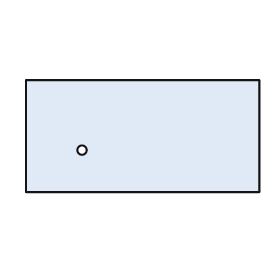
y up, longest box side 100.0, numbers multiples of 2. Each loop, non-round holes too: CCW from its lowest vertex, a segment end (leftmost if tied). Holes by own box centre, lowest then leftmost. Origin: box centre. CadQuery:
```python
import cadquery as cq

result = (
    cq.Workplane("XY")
    .moveTo(-50.0, -24.0)
    .lineTo(50.0, -24.0)
    .lineTo(50.0, 24.0)
    .lineTo(-50.0, 24.0)
    .close()
    .moveTo(-26.0, -6.0)
    .circle(2.0)
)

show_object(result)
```